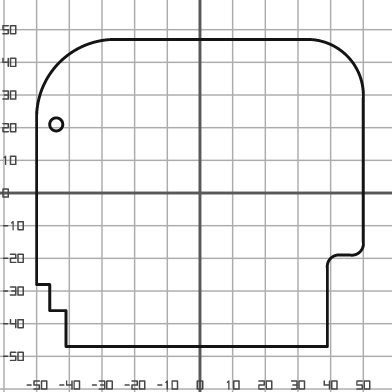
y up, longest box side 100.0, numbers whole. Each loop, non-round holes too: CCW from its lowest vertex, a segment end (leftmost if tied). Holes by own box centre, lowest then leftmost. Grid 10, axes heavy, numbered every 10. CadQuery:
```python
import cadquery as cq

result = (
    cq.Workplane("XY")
    .moveTo(-41.0, -47.0)
    .lineTo(39.0, -47.0)
    .lineTo(39.0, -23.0)
    .threePointArc((40.0, -20.0), (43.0, -19.0))
    .lineTo(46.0, -19.0)
    .threePointArc((49.0, -18.0), (50.0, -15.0))
    .lineTo(50.0, 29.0)
    .threePointArc((45.0, 42.0), (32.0, 47.0))
    .lineTo(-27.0, 47.0)
    .threePointArc((-43.0, 40.0), (-50.0, 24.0))
    .lineTo(-50.0, -28.0)
    .lineTo(-46.0, -28.0)
    .lineTo(-46.0, -36.0)
    .lineTo(-41.0, -36.0)
    .close()
    .moveTo(-44.0, 21.0)
    .circle(2.0)
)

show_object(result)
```